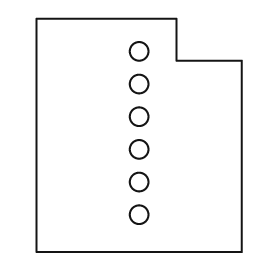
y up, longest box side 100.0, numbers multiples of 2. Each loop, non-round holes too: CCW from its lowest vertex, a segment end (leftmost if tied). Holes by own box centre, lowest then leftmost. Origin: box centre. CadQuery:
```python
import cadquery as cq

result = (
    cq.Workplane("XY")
    .moveTo(-44.0, -50.0)
    .lineTo(44.0, -50.0)
    .lineTo(44.0, 32.0)
    .lineTo(16.0, 32.0)
    .lineTo(16.0, 50.0)
    .lineTo(-44.0, 50.0)
    .close()
    .moveTo(0.0, -34.0)
    .circle(4.0)
    .moveTo(0.0, -20.0)
    .circle(4.0)
    .moveTo(0.0, -6.0)
    .circle(4.0)
    .moveTo(0.0, 8.0)
    .circle(4.0)
    .moveTo(0.0, 22.0)
    .circle(4.0)
    .moveTo(0.0, 36.0)
    .circle(4.0)
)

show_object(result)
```